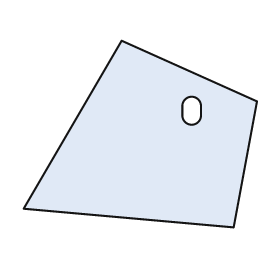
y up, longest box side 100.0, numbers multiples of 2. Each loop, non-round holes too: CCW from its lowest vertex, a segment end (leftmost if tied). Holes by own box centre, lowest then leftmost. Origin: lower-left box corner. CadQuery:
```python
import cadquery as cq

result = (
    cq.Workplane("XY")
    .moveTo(90.0, 0.0)
    .lineTo(100.0, 54.0)
    .lineTo(42.0, 80.0)
    .lineTo(0.0, 8.0)
    .close()
    .moveTo(68.0, 48.0)
    .threePointArc((72.0, 44.0), (76.0, 48.0))
    .lineTo(76.0, 52.0)
    .threePointArc((72.0, 56.0), (68.0, 52.0))
    .close()
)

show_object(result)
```